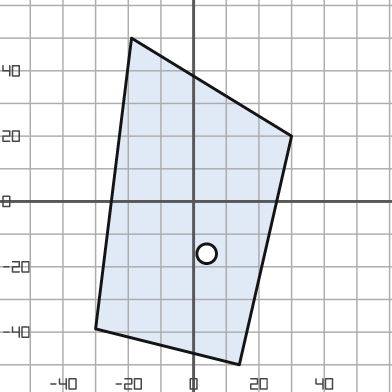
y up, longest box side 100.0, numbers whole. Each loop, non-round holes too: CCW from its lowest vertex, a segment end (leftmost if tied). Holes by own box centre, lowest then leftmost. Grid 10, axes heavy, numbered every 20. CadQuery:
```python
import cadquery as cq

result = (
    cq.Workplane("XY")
    .moveTo(14.0, -50.0)
    .lineTo(30.0, 20.0)
    .lineTo(-19.0, 50.0)
    .lineTo(-30.0, -39.0)
    .close()
    .moveTo(4.0, -16.0)
    .circle(3.0)
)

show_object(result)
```